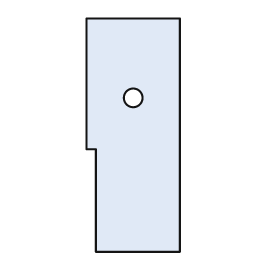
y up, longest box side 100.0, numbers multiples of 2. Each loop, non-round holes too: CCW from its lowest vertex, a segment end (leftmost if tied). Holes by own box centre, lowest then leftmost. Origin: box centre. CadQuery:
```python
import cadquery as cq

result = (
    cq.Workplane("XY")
    .moveTo(-16.0, -50.0)
    .lineTo(20.0, -50.0)
    .lineTo(20.0, 50.0)
    .lineTo(-20.0, 50.0)
    .lineTo(-20.0, -6.0)
    .lineTo(-16.0, -6.0)
    .close()
    .moveTo(0.0, 16.0)
    .circle(4.0)
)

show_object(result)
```